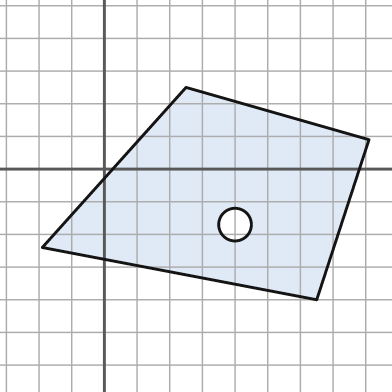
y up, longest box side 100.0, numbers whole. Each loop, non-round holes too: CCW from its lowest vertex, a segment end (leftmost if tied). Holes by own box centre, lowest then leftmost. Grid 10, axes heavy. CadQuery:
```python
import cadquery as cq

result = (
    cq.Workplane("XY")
    .moveTo(65.0, -40.0)
    .lineTo(81.0, 9.0)
    .lineTo(25.0, 25.0)
    .lineTo(-19.0, -24.0)
    .close()
    .moveTo(40.0, -17.0)
    .circle(5.0)
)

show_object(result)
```